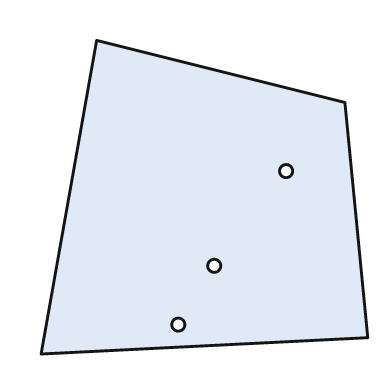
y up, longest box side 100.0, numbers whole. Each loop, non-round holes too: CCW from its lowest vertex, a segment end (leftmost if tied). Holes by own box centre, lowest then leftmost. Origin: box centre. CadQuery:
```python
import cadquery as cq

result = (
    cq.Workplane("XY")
    .moveTo(-50.0, -48.0)
    .lineTo(50.0, -43.0)
    .lineTo(43.0, 29.0)
    .lineTo(-33.0, 48.0)
    .close()
    .moveTo(-8.0, -39.0)
    .circle(2.0)
    .moveTo(3.0, -21.0)
    .circle(2.0)
    .moveTo(25.0, 8.0)
    .circle(2.0)
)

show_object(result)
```